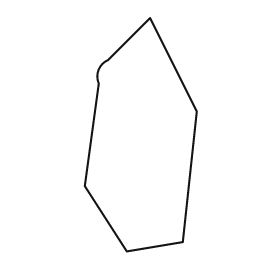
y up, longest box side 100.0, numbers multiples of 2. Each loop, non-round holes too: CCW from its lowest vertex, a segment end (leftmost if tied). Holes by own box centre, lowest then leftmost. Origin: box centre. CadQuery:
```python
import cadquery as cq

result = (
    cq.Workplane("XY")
    .moveTo(-6.0, -50.0)
    .lineTo(18.0, -46.0)
    .lineTo(24.0, 10.0)
    .lineTo(4.0, 50.0)
    .lineTo(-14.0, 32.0)
    .threePointArc((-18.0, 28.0), (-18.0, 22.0))
    .lineTo(-24.0, -22.0)
    .close()
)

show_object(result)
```